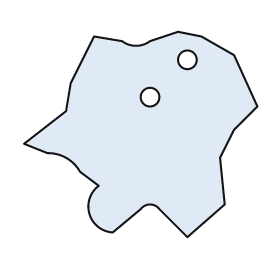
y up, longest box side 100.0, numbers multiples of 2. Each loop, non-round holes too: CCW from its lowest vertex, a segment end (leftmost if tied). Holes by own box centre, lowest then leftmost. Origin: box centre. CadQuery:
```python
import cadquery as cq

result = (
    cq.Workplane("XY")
    .moveTo(20.0, -44.0)
    .lineTo(36.0, -30.0)
    .lineTo(34.0, -10.0)
    .lineTo(40.0, 2.0)
    .lineTo(50.0, 12.0)
    .lineTo(40.0, 34.0)
    .lineTo(26.0, 42.0)
    .lineTo(16.0, 44.0)
    .lineTo(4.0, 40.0)
    .threePointArc((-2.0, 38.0), (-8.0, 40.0))
    .lineTo(-20.0, 42.0)
    .lineTo(-30.0, 22.0)
    .lineTo(-32.0, 10.0)
    .lineTo(-50.0, -4.0)
    .lineTo(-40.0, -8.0)
    .threePointArc((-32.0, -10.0), (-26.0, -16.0))
    .lineTo(-18.0, -22.0)
    .threePointArc((-22.0, -34.0), (-12.0, -42.0))
    .lineTo(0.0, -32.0)
    .threePointArc((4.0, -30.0), (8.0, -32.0))
    .close()
    .moveTo(4.0, 16.0)
    .circle(4.0)
    .moveTo(20.0, 32.0)
    .circle(4.0)
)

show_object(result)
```